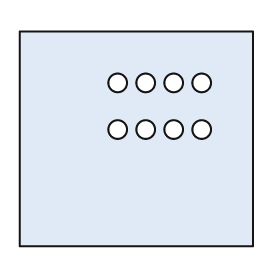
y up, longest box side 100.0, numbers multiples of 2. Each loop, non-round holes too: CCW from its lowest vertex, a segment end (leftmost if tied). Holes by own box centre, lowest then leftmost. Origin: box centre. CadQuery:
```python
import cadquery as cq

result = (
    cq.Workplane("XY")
    .moveTo(-50.0, -46.0)
    .lineTo(50.0, -46.0)
    .lineTo(50.0, 46.0)
    .lineTo(-50.0, 46.0)
    .close()
    .moveTo(-8.0, 4.0)
    .circle(4.0)
    .moveTo(4.0, 4.0)
    .circle(4.0)
    .moveTo(16.0, 4.0)
    .circle(4.0)
    .moveTo(28.0, 4.0)
    .circle(4.0)
    .moveTo(-8.0, 24.0)
    .circle(4.0)
    .moveTo(4.0, 24.0)
    .circle(4.0)
    .moveTo(16.0, 24.0)
    .circle(4.0)
    .moveTo(28.0, 24.0)
    .circle(4.0)
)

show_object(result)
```